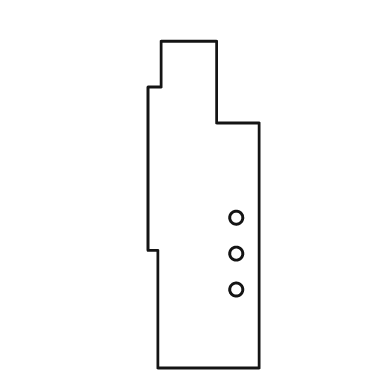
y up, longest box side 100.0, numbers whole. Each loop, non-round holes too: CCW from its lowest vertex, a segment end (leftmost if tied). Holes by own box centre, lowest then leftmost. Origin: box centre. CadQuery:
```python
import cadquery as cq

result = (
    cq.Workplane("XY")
    .moveTo(-14.0, -50.0)
    .lineTo(17.0, -50.0)
    .lineTo(17.0, 25.0)
    .lineTo(4.0, 25.0)
    .lineTo(4.0, 50.0)
    .lineTo(-13.0, 50.0)
    .lineTo(-13.0, 36.0)
    .lineTo(-17.0, 36.0)
    .lineTo(-17.0, -14.0)
    .lineTo(-14.0, -14.0)
    .close()
    .moveTo(10.0, -26.0)
    .circle(2.0)
    .moveTo(10.0, -15.0)
    .circle(2.0)
    .moveTo(10.0, -4.0)
    .circle(2.0)
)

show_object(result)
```